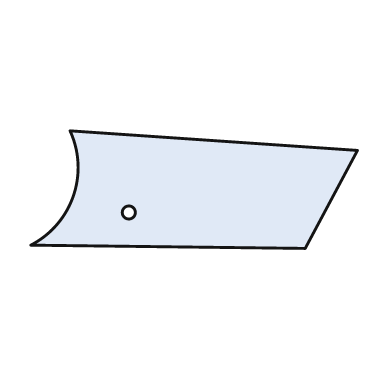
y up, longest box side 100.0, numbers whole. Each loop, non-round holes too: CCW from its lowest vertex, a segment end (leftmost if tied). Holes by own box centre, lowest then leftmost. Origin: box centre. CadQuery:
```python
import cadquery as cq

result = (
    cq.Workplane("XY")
    .moveTo(34.0, -18.0)
    .lineTo(50.0, 12.0)
    .lineTo(-38.0, 18.0)
    .threePointArc((-37.0, -2.0), (-50.0, -17.0))
    .close()
    .moveTo(-20.0, -7.0)
    .circle(2.0)
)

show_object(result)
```